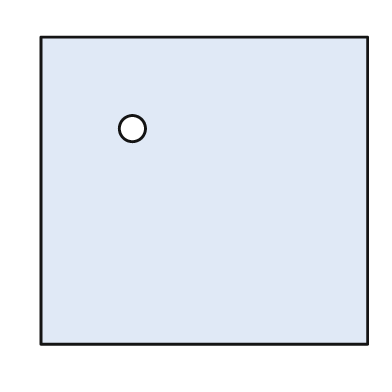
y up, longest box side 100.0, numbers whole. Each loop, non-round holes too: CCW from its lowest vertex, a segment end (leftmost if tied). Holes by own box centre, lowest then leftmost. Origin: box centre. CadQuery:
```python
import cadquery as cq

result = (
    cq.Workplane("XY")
    .moveTo(-50.0, -47.0)
    .lineTo(50.0, -47.0)
    .lineTo(50.0, 47.0)
    .lineTo(-50.0, 47.0)
    .close()
    .moveTo(-22.0, 19.0)
    .circle(4.0)
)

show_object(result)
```